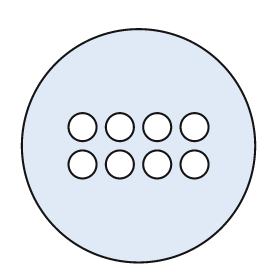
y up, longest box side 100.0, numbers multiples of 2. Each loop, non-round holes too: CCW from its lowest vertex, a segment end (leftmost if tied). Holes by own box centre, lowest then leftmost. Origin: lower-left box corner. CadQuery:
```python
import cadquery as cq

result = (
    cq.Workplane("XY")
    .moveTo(50.0, 50.0)
    .circle(50.0)
    .moveTo(26.0, 42.0)
    .circle(6.0)
    .moveTo(42.0, 42.0)
    .circle(6.0)
    .moveTo(58.0, 42.0)
    .circle(6.0)
    .moveTo(74.0, 42.0)
    .circle(6.0)
    .moveTo(26.0, 58.0)
    .circle(6.0)
    .moveTo(42.0, 58.0)
    .circle(6.0)
    .moveTo(58.0, 58.0)
    .circle(6.0)
    .moveTo(74.0, 58.0)
    .circle(6.0)
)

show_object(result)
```